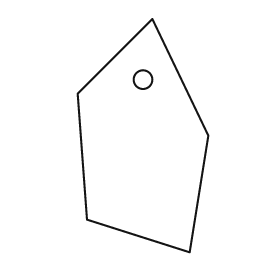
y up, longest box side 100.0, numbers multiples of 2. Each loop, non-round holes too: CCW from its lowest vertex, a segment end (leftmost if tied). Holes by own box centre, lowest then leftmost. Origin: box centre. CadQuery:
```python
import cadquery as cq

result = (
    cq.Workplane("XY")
    .moveTo(20.0, -50.0)
    .lineTo(28.0, 0.0)
    .lineTo(4.0, 50.0)
    .lineTo(-28.0, 18.0)
    .lineTo(-24.0, -36.0)
    .close()
    .moveTo(0.0, 24.0)
    .circle(4.0)
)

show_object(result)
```